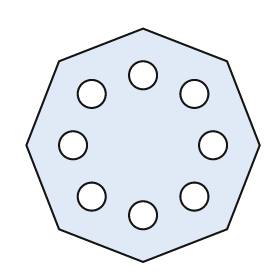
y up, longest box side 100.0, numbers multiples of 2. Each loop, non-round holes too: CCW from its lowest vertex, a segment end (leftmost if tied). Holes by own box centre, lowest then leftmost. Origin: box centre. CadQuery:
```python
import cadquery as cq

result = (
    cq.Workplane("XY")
    .moveTo(0.0, -50.0)
    .lineTo(36.0, -36.0)
    .lineTo(50.0, 0.0)
    .lineTo(36.0, 36.0)
    .lineTo(0.0, 50.0)
    .lineTo(-36.0, 36.0)
    .lineTo(-50.0, 0.0)
    .lineTo(-36.0, -36.0)
    .close()
    .moveTo(0.0, -30.0)
    .circle(6.0)
    .moveTo(-22.0, -22.0)
    .circle(6.0)
    .moveTo(22.0, -22.0)
    .circle(6.0)
    .moveTo(-30.0, 0.0)
    .circle(6.0)
    .moveTo(30.0, 0.0)
    .circle(6.0)
    .moveTo(-22.0, 22.0)
    .circle(6.0)
    .moveTo(22.0, 22.0)
    .circle(6.0)
    .moveTo(0.0, 30.0)
    .circle(6.0)
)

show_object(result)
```